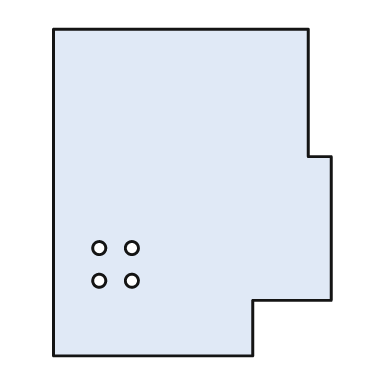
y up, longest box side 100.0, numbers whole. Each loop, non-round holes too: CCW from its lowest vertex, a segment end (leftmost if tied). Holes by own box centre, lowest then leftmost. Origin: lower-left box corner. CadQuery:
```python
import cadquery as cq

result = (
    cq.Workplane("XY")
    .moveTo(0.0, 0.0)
    .lineTo(61.0, 0.0)
    .lineTo(61.0, 17.0)
    .lineTo(85.0, 17.0)
    .lineTo(85.0, 61.0)
    .lineTo(78.0, 61.0)
    .lineTo(78.0, 100.0)
    .lineTo(0.0, 100.0)
    .close()
    .moveTo(14.0, 23.0)
    .circle(2.0)
    .moveTo(24.0, 23.0)
    .circle(2.0)
    .moveTo(14.0, 33.0)
    .circle(2.0)
    .moveTo(24.0, 33.0)
    .circle(2.0)
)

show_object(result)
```